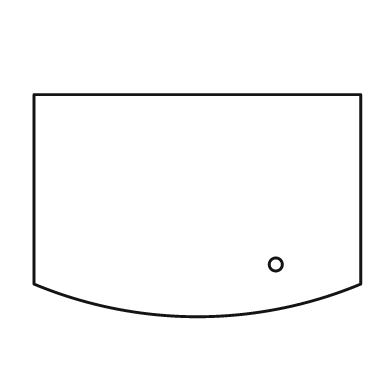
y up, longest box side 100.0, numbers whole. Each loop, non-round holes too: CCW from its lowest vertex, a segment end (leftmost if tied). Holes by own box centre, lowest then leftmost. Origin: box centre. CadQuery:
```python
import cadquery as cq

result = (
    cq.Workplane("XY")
    .moveTo(-50.0, -24.0)
    .threePointArc((0.0, -34.0), (50.0, -24.0))
    .lineTo(50.0, 34.0)
    .lineTo(-50.0, 34.0)
    .close()
    .moveTo(24.0, -18.0)
    .circle(2.0)
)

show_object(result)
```